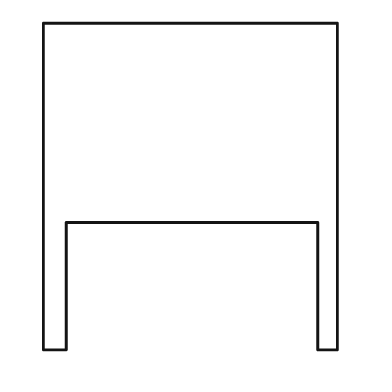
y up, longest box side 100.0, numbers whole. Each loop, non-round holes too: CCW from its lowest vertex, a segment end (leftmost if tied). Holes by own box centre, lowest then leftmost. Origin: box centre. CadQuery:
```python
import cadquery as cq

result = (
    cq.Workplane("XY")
    .moveTo(-45.0, -50.0)
    .lineTo(-38.0, -50.0)
    .lineTo(-38.0, -11.0)
    .lineTo(39.0, -11.0)
    .lineTo(39.0, -50.0)
    .lineTo(45.0, -50.0)
    .lineTo(45.0, 50.0)
    .lineTo(-45.0, 50.0)
    .close()
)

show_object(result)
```